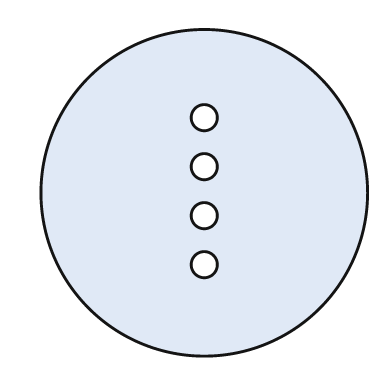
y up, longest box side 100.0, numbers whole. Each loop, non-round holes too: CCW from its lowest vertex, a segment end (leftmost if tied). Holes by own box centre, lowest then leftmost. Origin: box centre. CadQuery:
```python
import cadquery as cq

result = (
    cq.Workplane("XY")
    .moveTo(0.0, 0.0)
    .circle(50.0)
    .moveTo(0.0, -22.0)
    .circle(4.0)
    .moveTo(0.0, -7.0)
    .circle(4.0)
    .moveTo(0.0, 8.0)
    .circle(4.0)
    .moveTo(0.0, 23.0)
    .circle(4.0)
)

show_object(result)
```